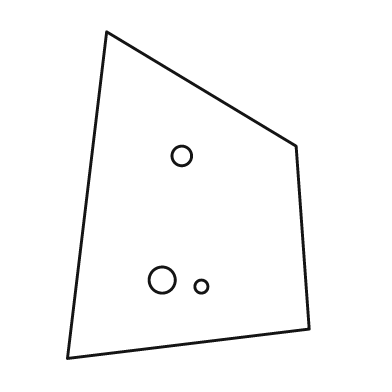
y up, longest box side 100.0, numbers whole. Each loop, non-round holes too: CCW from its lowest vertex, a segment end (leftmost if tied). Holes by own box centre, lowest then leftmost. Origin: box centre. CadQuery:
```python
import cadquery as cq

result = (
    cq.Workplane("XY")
    .moveTo(-37.0, -50.0)
    .lineTo(37.0, -41.0)
    .lineTo(33.0, 15.0)
    .lineTo(-25.0, 50.0)
    .close()
    .moveTo(4.0, -28.0)
    .circle(2.0)
    .moveTo(-8.0, -26.0)
    .circle(4.0)
    .moveTo(-2.0, 12.0)
    .circle(3.0)
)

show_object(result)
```